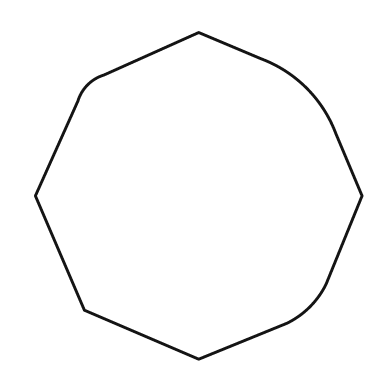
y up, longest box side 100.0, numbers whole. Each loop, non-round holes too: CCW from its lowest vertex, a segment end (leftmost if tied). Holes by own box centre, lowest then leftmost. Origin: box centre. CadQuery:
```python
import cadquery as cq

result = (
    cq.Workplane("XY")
    .moveTo(0.0, -50.0)
    .lineTo(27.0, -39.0)
    .threePointArc((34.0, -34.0), (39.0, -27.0))
    .lineTo(50.0, 0.0)
    .lineTo(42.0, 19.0)
    .threePointArc((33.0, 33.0), (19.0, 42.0))
    .lineTo(0.0, 50.0)
    .lineTo(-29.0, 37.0)
    .threePointArc((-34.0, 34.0), (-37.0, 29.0))
    .lineTo(-50.0, 0.0)
    .lineTo(-35.0, -35.0)
    .close()
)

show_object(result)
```